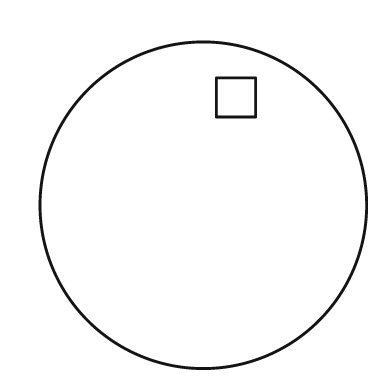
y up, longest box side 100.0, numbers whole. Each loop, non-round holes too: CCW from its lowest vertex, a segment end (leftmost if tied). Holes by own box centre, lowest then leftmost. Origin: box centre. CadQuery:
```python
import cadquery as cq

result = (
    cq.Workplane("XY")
    .moveTo(0.0, 0.0)
    .circle(50.0)
    .moveTo(4.0, 27.0)
    .lineTo(16.0, 27.0)
    .lineTo(16.0, 39.0)
    .lineTo(4.0, 39.0)
    .close()
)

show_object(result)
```